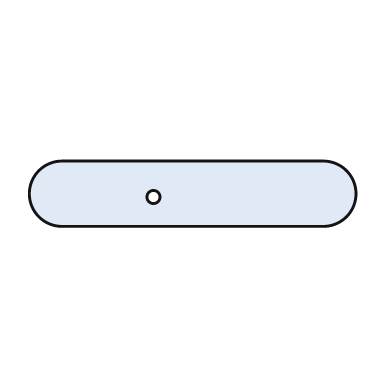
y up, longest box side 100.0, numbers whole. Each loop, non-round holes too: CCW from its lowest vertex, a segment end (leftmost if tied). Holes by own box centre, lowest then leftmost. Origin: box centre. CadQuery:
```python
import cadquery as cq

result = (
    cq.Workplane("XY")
    .moveTo(-40.0, -10.0)
    .lineTo(40.0, -10.0)
    .threePointArc((50.0, 0.0), (40.0, 10.0))
    .lineTo(-40.0, 10.0)
    .threePointArc((-50.0, 0.0), (-40.0, -10.0))
    .close()
    .moveTo(-12.0, -1.0)
    .circle(2.0)
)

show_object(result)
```